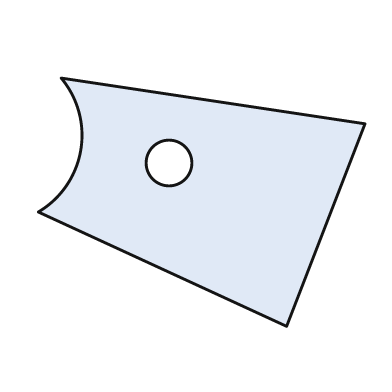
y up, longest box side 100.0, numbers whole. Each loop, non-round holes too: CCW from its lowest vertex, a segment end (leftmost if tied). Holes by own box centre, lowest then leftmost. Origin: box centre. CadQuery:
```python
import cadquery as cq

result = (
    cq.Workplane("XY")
    .moveTo(26.0, -38.0)
    .lineTo(50.0, 24.0)
    .lineTo(-43.0, 38.0)
    .threePointArc((-37.0, 16.0), (-50.0, -3.0))
    .close()
    .moveTo(-10.0, 12.0)
    .circle(7.0)
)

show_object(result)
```